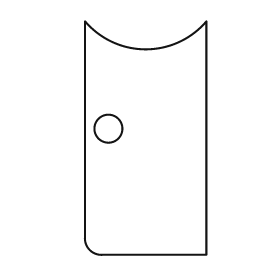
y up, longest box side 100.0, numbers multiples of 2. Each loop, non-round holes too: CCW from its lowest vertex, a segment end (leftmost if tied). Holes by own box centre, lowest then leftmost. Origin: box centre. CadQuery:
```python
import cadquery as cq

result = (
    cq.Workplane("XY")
    .moveTo(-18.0, -50.0)
    .lineTo(26.0, -50.0)
    .lineTo(26.0, 50.0)
    .threePointArc((0.0, 38.0), (-26.0, 50.0))
    .lineTo(-26.0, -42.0)
    .threePointArc((-24.0, -48.0), (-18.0, -50.0))
    .close()
    .moveTo(-16.0, 4.0)
    .circle(6.0)
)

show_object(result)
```